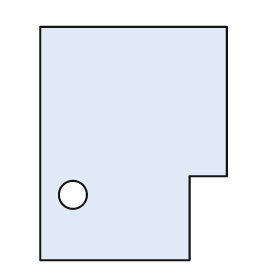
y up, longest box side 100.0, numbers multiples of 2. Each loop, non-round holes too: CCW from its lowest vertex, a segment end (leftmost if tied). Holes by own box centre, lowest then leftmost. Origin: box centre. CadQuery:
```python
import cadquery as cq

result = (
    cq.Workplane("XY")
    .moveTo(-40.0, -50.0)
    .lineTo(24.0, -50.0)
    .lineTo(24.0, -14.0)
    .lineTo(40.0, -14.0)
    .lineTo(40.0, 50.0)
    .lineTo(-40.0, 50.0)
    .close()
    .moveTo(-26.0, -22.0)
    .circle(6.0)
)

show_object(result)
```